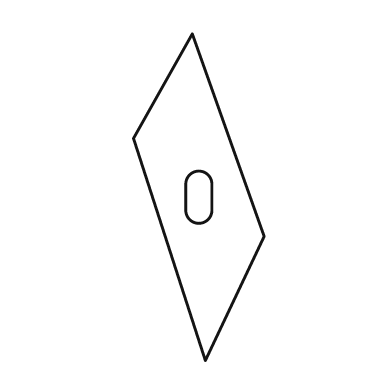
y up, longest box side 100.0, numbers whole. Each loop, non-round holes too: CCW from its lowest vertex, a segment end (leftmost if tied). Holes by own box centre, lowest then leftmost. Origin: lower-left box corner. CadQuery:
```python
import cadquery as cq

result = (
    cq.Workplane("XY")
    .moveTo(22.0, 0.0)
    .lineTo(40.0, 38.0)
    .lineTo(18.0, 100.0)
    .lineTo(0.0, 68.0)
    .close()
    .moveTo(16.0, 46.0)
    .threePointArc((20.0, 42.0), (24.0, 46.0))
    .lineTo(24.0, 54.0)
    .threePointArc((20.0, 58.0), (16.0, 54.0))
    .close()
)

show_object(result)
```